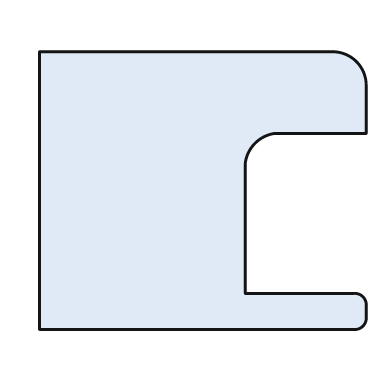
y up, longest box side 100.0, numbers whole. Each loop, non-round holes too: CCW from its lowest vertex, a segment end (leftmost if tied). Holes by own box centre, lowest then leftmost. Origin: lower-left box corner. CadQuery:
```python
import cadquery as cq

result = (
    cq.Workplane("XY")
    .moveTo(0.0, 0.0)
    .lineTo(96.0, 0.0)
    .threePointArc((99.0, 1.0), (100.0, 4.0))
    .lineTo(100.0, 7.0)
    .threePointArc((99.0, 10.0), (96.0, 11.0))
    .lineTo(63.0, 11.0)
    .lineTo(63.0, 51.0)
    .threePointArc((66.0, 57.0), (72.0, 60.0))
    .lineTo(100.0, 60.0)
    .lineTo(100.0, 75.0)
    .threePointArc((97.0, 82.0), (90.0, 85.0))
    .lineTo(0.0, 85.0)
    .close()
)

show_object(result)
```